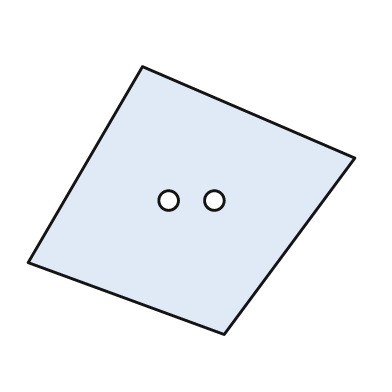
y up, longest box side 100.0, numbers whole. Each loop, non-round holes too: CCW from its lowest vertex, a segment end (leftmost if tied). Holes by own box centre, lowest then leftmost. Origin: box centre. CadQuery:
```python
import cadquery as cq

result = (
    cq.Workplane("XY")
    .moveTo(10.0, -41.0)
    .lineTo(50.0, 13.0)
    .lineTo(-15.0, 41.0)
    .lineTo(-50.0, -19.0)
    .close()
    .moveTo(-7.0, 0.0)
    .circle(3.0)
    .moveTo(7.0, 0.0)
    .circle(3.0)
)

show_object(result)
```